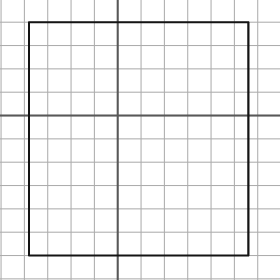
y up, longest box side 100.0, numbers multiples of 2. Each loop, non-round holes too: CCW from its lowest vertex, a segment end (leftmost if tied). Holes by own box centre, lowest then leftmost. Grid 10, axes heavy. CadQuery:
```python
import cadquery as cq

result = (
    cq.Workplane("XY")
    .moveTo(-38.0, -60.0)
    .lineTo(56.0, -60.0)
    .lineTo(56.0, 40.0)
    .lineTo(-38.0, 40.0)
    .close()
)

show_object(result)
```